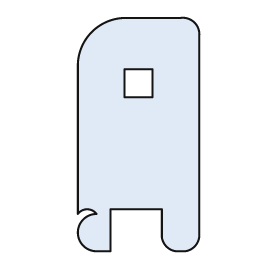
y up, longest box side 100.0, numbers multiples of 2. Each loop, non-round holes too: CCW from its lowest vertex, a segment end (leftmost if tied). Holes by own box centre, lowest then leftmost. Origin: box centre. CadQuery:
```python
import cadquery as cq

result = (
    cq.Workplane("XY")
    .moveTo(-18.0, -50.0)
    .lineTo(-12.0, -50.0)
    .lineTo(-12.0, -32.0)
    .lineTo(10.0, -32.0)
    .lineTo(10.0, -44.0)
    .threePointArc((12.0, -48.0), (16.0, -50.0))
    .lineTo(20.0, -50.0)
    .threePointArc((24.0, -48.0), (26.0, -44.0))
    .lineTo(26.0, 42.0)
    .threePointArc((24.0, 48.0), (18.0, 50.0))
    .lineTo(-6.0, 50.0)
    .threePointArc((-20.0, 44.0), (-26.0, 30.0))
    .lineTo(-26.0, -34.0)
    .threePointArc((-22.0, -32.0), (-18.0, -34.0))
    .threePointArc((-26.0, -42.0), (-18.0, -50.0))
    .close()
    .moveTo(-6.0, 16.0)
    .lineTo(6.0, 16.0)
    .lineTo(6.0, 28.0)
    .lineTo(-6.0, 28.0)
    .close()
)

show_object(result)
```